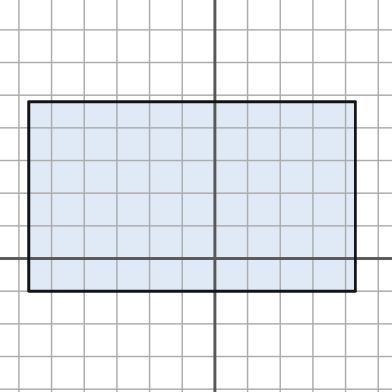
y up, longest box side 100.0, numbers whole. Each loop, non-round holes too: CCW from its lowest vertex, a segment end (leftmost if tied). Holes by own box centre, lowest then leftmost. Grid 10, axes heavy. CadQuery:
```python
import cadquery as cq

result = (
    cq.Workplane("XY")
    .moveTo(-57.0, -10.0)
    .lineTo(43.0, -10.0)
    .lineTo(43.0, 48.0)
    .lineTo(-57.0, 48.0)
    .close()
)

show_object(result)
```